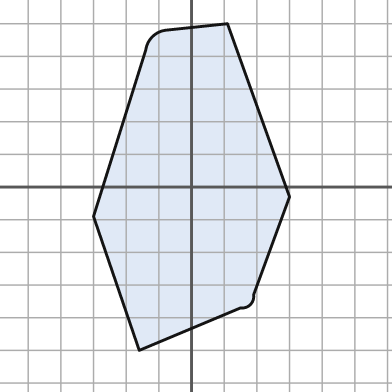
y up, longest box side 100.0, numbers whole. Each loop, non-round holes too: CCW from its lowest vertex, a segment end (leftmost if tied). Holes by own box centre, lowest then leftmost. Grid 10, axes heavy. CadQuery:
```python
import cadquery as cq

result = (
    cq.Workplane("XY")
    .moveTo(-16.0, -50.0)
    .lineTo(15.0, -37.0)
    .threePointArc((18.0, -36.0), (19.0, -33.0))
    .lineTo(30.0, -3.0)
    .lineTo(11.0, 50.0)
    .lineTo(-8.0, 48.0)
    .threePointArc((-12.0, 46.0), (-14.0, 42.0))
    .lineTo(-30.0, -9.0)
    .close()
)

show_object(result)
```